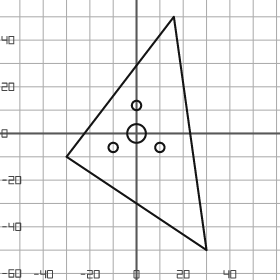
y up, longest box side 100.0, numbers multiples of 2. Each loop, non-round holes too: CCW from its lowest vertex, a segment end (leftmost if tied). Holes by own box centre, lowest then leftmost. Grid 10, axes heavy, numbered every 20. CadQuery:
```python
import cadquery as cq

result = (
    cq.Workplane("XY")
    .moveTo(30.0, -50.0)
    .lineTo(16.0, 50.0)
    .lineTo(-30.0, -10.0)
    .close()
    .moveTo(-10.0, -6.0)
    .circle(2.0)
    .moveTo(10.0, -6.0)
    .circle(2.0)
    .moveTo(0.0, 0.0)
    .circle(4.0)
    .moveTo(0.0, 12.0)
    .circle(2.0)
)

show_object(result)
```